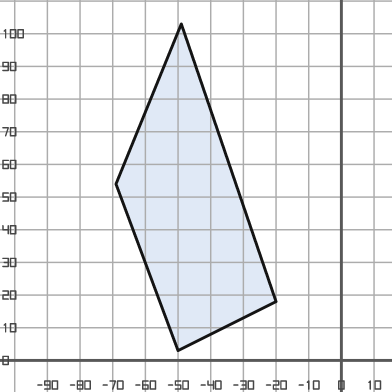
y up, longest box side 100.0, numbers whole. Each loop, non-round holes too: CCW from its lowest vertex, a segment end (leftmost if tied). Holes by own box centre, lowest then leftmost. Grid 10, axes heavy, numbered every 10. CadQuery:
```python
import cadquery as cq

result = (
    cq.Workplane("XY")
    .moveTo(-50.0, 3.0)
    .lineTo(-20.0, 18.0)
    .lineTo(-49.0, 103.0)
    .lineTo(-69.0, 54.0)
    .close()
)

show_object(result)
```